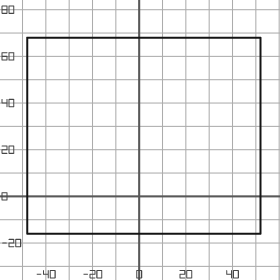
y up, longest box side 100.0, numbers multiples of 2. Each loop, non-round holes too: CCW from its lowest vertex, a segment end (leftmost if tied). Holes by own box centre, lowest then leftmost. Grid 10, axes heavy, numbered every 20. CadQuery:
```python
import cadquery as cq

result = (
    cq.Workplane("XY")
    .moveTo(-48.0, -16.0)
    .lineTo(52.0, -16.0)
    .lineTo(52.0, 68.0)
    .lineTo(-48.0, 68.0)
    .close()
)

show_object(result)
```